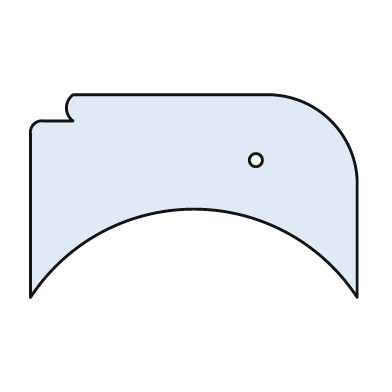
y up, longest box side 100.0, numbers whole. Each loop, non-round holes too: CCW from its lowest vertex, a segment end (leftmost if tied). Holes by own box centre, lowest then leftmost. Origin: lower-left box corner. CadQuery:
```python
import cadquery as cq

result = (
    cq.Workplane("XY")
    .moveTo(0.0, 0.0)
    .threePointArc((50.0, 27.0), (100.0, 0.0))
    .lineTo(100.0, 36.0)
    .threePointArc((92.0, 54.0), (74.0, 62.0))
    .lineTo(13.0, 62.0)
    .threePointArc((11.0, 58.0), (13.0, 54.0))
    .lineTo(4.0, 54.0)
    .threePointArc((1.0, 53.0), (0.0, 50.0))
    .close()
    .moveTo(69.0, 42.0)
    .circle(2.0)
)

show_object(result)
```